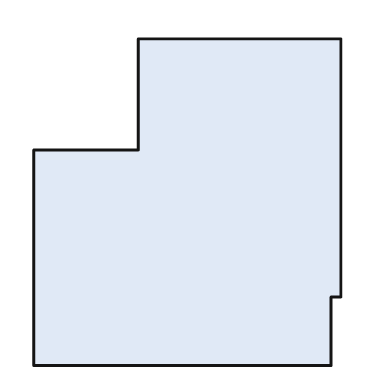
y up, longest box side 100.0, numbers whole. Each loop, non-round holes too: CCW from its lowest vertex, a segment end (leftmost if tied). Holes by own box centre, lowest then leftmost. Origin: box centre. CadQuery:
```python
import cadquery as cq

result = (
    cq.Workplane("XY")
    .moveTo(-47.0, -50.0)
    .lineTo(44.0, -50.0)
    .lineTo(44.0, -29.0)
    .lineTo(47.0, -29.0)
    .lineTo(47.0, 50.0)
    .lineTo(-15.0, 50.0)
    .lineTo(-15.0, 16.0)
    .lineTo(-47.0, 16.0)
    .close()
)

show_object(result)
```